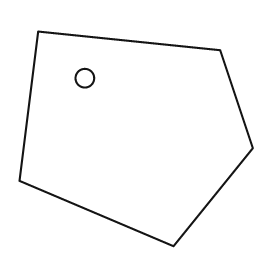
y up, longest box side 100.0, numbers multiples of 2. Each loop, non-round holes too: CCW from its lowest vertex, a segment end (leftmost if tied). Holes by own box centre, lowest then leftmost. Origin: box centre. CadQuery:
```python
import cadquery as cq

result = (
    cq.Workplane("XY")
    .moveTo(16.0, -46.0)
    .lineTo(50.0, -4.0)
    .lineTo(36.0, 38.0)
    .lineTo(-42.0, 46.0)
    .lineTo(-50.0, -18.0)
    .close()
    .moveTo(-22.0, 26.0)
    .circle(4.0)
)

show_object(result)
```